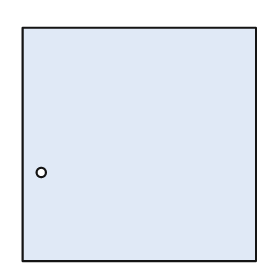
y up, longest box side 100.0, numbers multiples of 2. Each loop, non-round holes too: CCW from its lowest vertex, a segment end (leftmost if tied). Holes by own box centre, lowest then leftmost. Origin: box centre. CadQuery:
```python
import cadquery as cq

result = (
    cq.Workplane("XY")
    .moveTo(-50.0, -50.0)
    .lineTo(50.0, -50.0)
    .lineTo(50.0, 50.0)
    .lineTo(-50.0, 50.0)
    .close()
    .moveTo(-42.0, -12.0)
    .circle(2.0)
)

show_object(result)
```